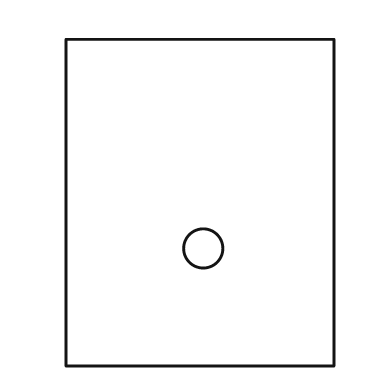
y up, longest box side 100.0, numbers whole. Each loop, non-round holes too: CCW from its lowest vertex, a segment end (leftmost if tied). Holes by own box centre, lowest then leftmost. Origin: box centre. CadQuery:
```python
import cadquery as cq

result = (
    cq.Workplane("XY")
    .moveTo(-41.0, -50.0)
    .lineTo(41.0, -50.0)
    .lineTo(41.0, 50.0)
    .lineTo(-41.0, 50.0)
    .close()
    .moveTo(1.0, -14.0)
    .circle(6.0)
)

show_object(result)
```